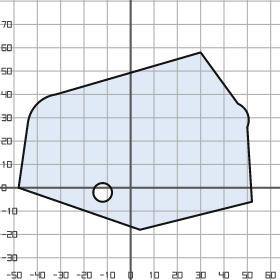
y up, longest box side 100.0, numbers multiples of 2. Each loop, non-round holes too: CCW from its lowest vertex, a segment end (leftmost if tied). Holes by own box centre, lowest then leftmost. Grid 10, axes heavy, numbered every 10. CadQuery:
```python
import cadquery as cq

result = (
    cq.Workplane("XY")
    .moveTo(4.0, -18.0)
    .lineTo(52.0, -6.0)
    .lineTo(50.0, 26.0)
    .threePointArc((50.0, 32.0), (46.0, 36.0))
    .lineTo(30.0, 58.0)
    .lineTo(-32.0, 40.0)
    .threePointArc((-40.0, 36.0), (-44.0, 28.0))
    .lineTo(-48.0, 0.0)
    .close()
    .moveTo(-12.0, -2.0)
    .circle(4.0)
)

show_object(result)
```